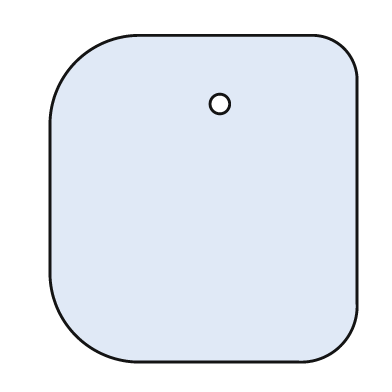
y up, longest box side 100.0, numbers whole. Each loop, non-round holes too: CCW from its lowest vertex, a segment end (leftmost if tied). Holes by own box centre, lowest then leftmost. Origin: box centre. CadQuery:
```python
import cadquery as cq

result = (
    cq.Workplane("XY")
    .moveTo(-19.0, -50.0)
    .lineTo(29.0, -50.0)
    .threePointArc((42.0, -45.0), (47.0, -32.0))
    .lineTo(47.0, 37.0)
    .threePointArc((43.0, 46.0), (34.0, 50.0))
    .lineTo(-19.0, 50.0)
    .threePointArc((-39.0, 42.0), (-47.0, 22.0))
    .lineTo(-47.0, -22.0)
    .threePointArc((-39.0, -42.0), (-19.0, -50.0))
    .close()
    .moveTo(5.0, 29.0)
    .circle(3.0)
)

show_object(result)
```